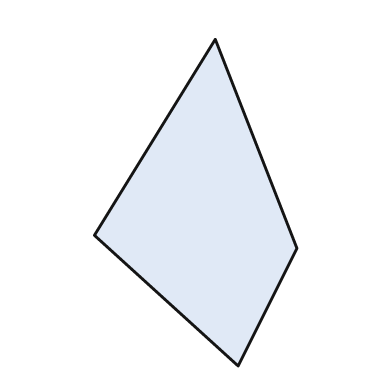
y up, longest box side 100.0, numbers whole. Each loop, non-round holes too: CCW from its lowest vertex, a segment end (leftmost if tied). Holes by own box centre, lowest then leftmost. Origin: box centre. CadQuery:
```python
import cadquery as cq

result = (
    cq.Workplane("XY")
    .moveTo(13.0, -50.0)
    .lineTo(31.0, -14.0)
    .lineTo(6.0, 50.0)
    .lineTo(-31.0, -10.0)
    .close()
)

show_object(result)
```